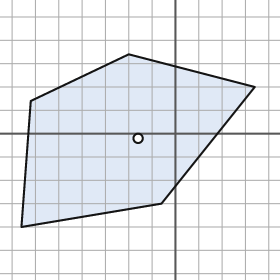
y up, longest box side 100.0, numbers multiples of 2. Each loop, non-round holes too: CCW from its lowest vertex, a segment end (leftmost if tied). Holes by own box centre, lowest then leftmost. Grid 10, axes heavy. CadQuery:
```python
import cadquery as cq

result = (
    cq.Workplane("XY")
    .moveTo(-66.0, -40.0)
    .lineTo(-6.0, -30.0)
    .lineTo(34.0, 20.0)
    .lineTo(-20.0, 34.0)
    .lineTo(-62.0, 14.0)
    .close()
    .moveTo(-16.0, -2.0)
    .circle(2.0)
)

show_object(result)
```